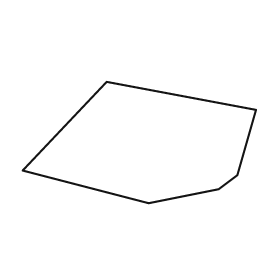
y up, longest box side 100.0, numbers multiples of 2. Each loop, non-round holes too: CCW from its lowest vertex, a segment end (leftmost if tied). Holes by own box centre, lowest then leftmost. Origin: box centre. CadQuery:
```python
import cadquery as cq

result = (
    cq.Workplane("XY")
    .moveTo(4.0, -26.0)
    .lineTo(34.0, -20.0)
    .lineTo(42.0, -14.0)
    .lineTo(50.0, 14.0)
    .lineTo(-14.0, 26.0)
    .lineTo(-50.0, -12.0)
    .close()
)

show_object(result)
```